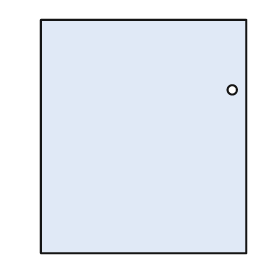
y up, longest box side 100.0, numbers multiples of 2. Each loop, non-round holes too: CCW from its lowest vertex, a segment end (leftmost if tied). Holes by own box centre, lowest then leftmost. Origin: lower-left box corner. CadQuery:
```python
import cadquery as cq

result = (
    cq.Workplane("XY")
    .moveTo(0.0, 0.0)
    .lineTo(88.0, 0.0)
    .lineTo(88.0, 100.0)
    .lineTo(0.0, 100.0)
    .close()
    .moveTo(82.0, 70.0)
    .circle(2.0)
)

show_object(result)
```